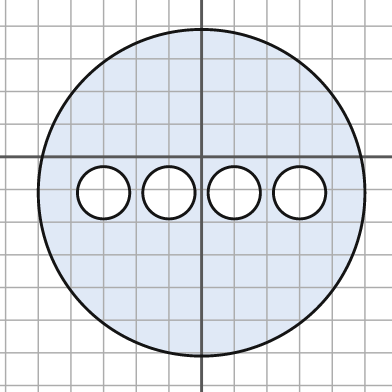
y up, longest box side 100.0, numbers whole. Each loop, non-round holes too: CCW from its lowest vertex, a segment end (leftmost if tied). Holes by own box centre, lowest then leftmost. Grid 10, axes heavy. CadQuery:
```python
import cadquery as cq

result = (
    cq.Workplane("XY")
    .moveTo(0.0, -11.0)
    .circle(50.0)
    .moveTo(-30.0, -11.0)
    .circle(8.0)
    .moveTo(-10.0, -11.0)
    .circle(8.0)
    .moveTo(10.0, -11.0)
    .circle(8.0)
    .moveTo(30.0, -11.0)
    .circle(8.0)
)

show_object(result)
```